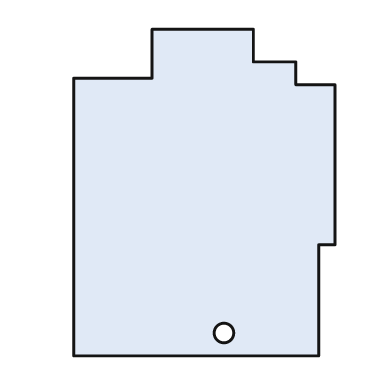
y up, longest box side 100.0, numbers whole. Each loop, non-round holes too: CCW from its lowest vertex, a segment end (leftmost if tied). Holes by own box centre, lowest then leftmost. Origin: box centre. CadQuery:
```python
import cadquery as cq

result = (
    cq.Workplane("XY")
    .moveTo(-40.0, -50.0)
    .lineTo(35.0, -50.0)
    .lineTo(35.0, -16.0)
    .lineTo(40.0, -16.0)
    .lineTo(40.0, 33.0)
    .lineTo(28.0, 33.0)
    .lineTo(28.0, 40.0)
    .lineTo(15.0, 40.0)
    .lineTo(15.0, 50.0)
    .lineTo(-16.0, 50.0)
    .lineTo(-16.0, 35.0)
    .lineTo(-40.0, 35.0)
    .close()
    .moveTo(6.0, -43.0)
    .circle(3.0)
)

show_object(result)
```